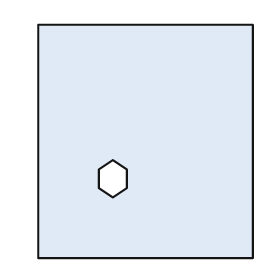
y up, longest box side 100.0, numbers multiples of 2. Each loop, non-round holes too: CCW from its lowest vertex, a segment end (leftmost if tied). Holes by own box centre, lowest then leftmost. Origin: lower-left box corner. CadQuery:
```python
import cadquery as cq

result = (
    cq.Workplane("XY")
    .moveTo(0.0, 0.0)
    .lineTo(92.0, 0.0)
    .lineTo(92.0, 100.0)
    .lineTo(0.0, 100.0)
    .close()
    .moveTo(32.0, 26.0)
    .lineTo(38.0, 30.0)
    .lineTo(38.0, 38.0)
    .lineTo(32.0, 42.0)
    .lineTo(26.0, 38.0)
    .lineTo(26.0, 30.0)
    .close()
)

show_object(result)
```